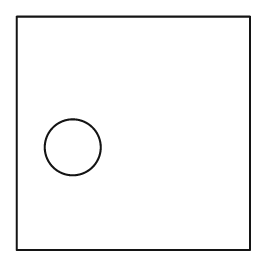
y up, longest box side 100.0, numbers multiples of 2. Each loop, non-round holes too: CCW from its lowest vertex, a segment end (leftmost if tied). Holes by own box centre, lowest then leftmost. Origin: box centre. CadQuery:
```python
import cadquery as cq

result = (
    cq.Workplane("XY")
    .moveTo(-50.0, -50.0)
    .lineTo(50.0, -50.0)
    .lineTo(50.0, 50.0)
    .lineTo(-50.0, 50.0)
    .close()
    .moveTo(-26.0, -6.0)
    .circle(12.0)
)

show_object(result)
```